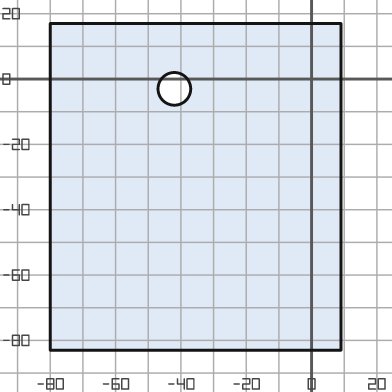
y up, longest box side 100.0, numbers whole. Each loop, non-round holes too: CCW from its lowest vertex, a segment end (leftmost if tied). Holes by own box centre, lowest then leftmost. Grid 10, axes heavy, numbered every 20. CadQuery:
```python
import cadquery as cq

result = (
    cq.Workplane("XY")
    .moveTo(-80.0, -83.0)
    .lineTo(9.0, -83.0)
    .lineTo(9.0, 17.0)
    .lineTo(-80.0, 17.0)
    .close()
    .moveTo(-42.0, -3.0)
    .circle(5.0)
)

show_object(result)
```